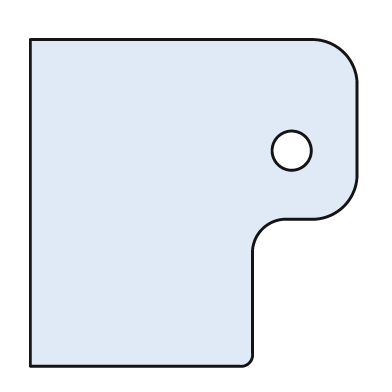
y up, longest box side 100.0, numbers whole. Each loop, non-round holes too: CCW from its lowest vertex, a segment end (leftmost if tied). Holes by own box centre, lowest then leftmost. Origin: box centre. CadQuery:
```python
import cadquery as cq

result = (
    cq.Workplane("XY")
    .moveTo(-50.0, -50.0)
    .lineTo(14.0, -50.0)
    .threePointArc((17.0, -49.0), (18.0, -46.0))
    .lineTo(18.0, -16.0)
    .threePointArc((21.0, -8.0), (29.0, -5.0))
    .lineTo(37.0, -5.0)
    .threePointArc((46.0, -1.0), (50.0, 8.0))
    .lineTo(50.0, 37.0)
    .threePointArc((46.0, 46.0), (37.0, 50.0))
    .lineTo(-50.0, 50.0)
    .close()
    .moveTo(30.0, 16.0)
    .circle(6.0)
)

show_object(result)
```